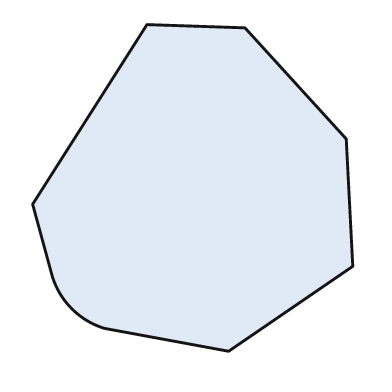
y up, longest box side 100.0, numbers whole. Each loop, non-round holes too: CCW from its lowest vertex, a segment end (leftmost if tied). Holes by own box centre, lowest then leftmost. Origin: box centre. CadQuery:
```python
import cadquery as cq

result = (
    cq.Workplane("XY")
    .moveTo(11.0, -50.0)
    .lineTo(49.0, -24.0)
    .lineTo(47.0, 15.0)
    .lineTo(16.0, 49.0)
    .lineTo(-14.0, 50.0)
    .lineTo(-49.0, -5.0)
    .lineTo(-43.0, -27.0)
    .threePointArc((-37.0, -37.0), (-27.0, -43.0))
    .close()
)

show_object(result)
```